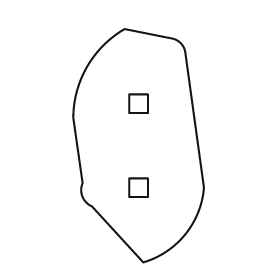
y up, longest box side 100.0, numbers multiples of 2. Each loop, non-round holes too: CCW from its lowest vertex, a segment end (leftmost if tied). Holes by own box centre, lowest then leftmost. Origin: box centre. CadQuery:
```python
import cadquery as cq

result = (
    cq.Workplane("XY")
    .moveTo(2.0, -50.0)
    .threePointArc((20.0, -38.0), (28.0, -18.0))
    .lineTo(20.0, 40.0)
    .threePointArc((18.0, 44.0), (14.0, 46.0))
    .lineTo(-6.0, 50.0)
    .threePointArc((-22.0, 34.0), (-28.0, 12.0))
    .lineTo(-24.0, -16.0)
    .threePointArc((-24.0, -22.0), (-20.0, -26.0))
    .close()
    .moveTo(-4.0, -22.0)
    .lineTo(4.0, -22.0)
    .lineTo(4.0, -14.0)
    .lineTo(-4.0, -14.0)
    .close()
    .moveTo(-4.0, 14.0)
    .lineTo(4.0, 14.0)
    .lineTo(4.0, 22.0)
    .lineTo(-4.0, 22.0)
    .close()
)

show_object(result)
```